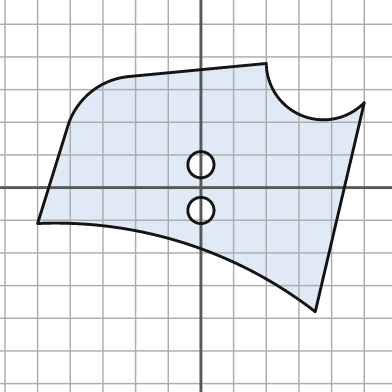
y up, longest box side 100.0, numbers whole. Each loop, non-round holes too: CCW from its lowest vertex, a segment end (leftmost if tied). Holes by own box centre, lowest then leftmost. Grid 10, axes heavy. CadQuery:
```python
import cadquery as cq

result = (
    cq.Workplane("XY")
    .moveTo(35.0, -38.0)
    .lineTo(50.0, 26.0)
    .threePointArc((31.0, 22.0), (20.0, 38.0))
    .lineTo(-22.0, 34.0)
    .threePointArc((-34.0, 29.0), (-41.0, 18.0))
    .lineTo(-50.0, -11.0)
    .threePointArc((-5.0, -17.0), (35.0, -38.0))
    .close()
    .moveTo(0.0, -7.0)
    .circle(4.0)
    .moveTo(0.0, 7.0)
    .circle(4.0)
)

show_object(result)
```